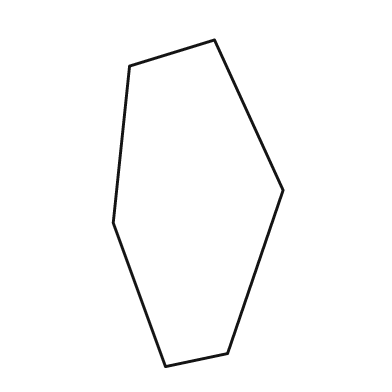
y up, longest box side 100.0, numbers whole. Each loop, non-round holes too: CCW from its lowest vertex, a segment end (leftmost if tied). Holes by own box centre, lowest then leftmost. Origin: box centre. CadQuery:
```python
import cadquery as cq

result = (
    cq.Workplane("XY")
    .moveTo(-10.0, -50.0)
    .lineTo(9.0, -46.0)
    .lineTo(26.0, 4.0)
    .lineTo(5.0, 50.0)
    .lineTo(-21.0, 42.0)
    .lineTo(-26.0, -6.0)
    .close()
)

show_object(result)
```